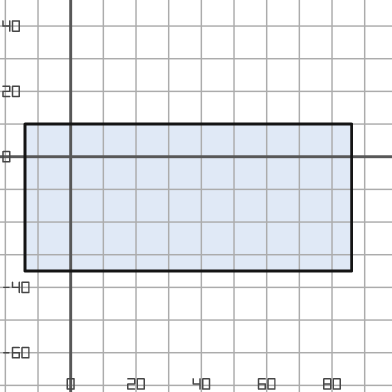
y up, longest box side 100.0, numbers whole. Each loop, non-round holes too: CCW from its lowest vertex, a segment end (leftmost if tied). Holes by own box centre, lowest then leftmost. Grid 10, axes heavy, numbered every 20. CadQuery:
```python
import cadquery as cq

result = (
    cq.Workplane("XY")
    .moveTo(-14.0, -35.0)
    .lineTo(86.0, -35.0)
    .lineTo(86.0, 10.0)
    .lineTo(-14.0, 10.0)
    .close()
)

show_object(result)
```